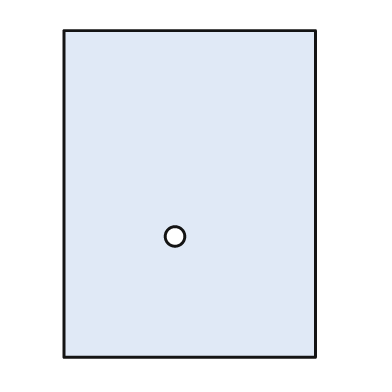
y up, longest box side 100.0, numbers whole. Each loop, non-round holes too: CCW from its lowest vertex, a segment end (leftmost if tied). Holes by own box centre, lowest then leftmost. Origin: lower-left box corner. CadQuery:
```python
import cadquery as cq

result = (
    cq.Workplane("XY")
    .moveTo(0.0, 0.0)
    .lineTo(77.0, 0.0)
    .lineTo(77.0, 100.0)
    .lineTo(0.0, 100.0)
    .close()
    .moveTo(34.0, 37.0)
    .circle(3.0)
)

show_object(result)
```